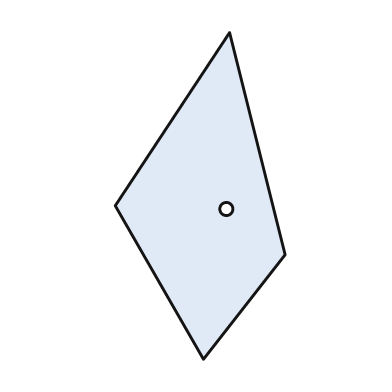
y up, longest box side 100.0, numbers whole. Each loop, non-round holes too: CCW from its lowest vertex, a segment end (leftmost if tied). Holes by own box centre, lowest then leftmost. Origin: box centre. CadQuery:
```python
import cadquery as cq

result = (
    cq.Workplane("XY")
    .moveTo(1.0, -50.0)
    .lineTo(26.0, -18.0)
    .lineTo(9.0, 50.0)
    .lineTo(-26.0, -3.0)
    .close()
    .moveTo(8.0, -4.0)
    .circle(2.0)
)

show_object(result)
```